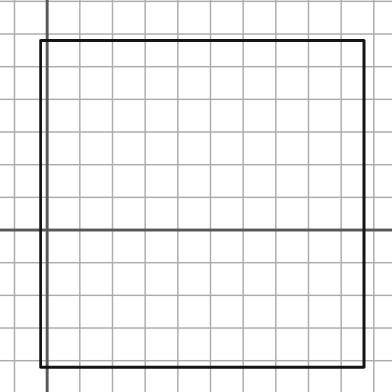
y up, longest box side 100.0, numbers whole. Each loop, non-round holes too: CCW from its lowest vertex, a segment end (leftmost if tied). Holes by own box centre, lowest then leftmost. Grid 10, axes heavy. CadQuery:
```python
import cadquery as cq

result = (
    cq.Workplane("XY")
    .moveTo(-2.0, -42.0)
    .lineTo(97.0, -42.0)
    .lineTo(97.0, 58.0)
    .lineTo(-2.0, 58.0)
    .close()
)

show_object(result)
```